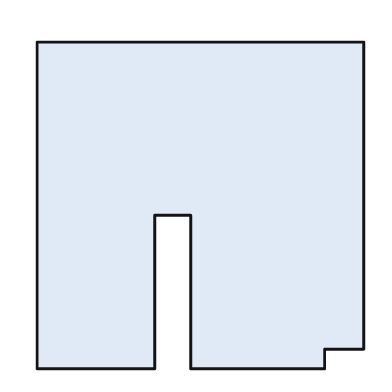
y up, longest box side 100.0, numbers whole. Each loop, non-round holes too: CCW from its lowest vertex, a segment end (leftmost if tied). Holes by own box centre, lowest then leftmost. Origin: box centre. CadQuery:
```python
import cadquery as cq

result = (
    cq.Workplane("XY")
    .moveTo(-50.0, -50.0)
    .lineTo(-14.0, -50.0)
    .lineTo(-14.0, -3.0)
    .lineTo(-3.0, -3.0)
    .lineTo(-3.0, -50.0)
    .lineTo(38.0, -50.0)
    .lineTo(38.0, -44.0)
    .lineTo(50.0, -44.0)
    .lineTo(50.0, 50.0)
    .lineTo(-50.0, 50.0)
    .close()
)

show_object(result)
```